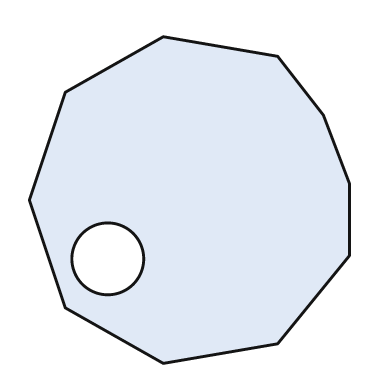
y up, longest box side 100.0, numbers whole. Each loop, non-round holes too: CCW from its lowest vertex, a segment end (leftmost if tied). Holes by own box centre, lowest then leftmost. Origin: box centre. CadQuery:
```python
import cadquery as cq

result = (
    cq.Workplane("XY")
    .moveTo(-8.0, -50.0)
    .lineTo(27.0, -44.0)
    .lineTo(49.0, -17.0)
    .lineTo(49.0, 5.0)
    .lineTo(41.0, 26.0)
    .lineTo(27.0, 44.0)
    .lineTo(-8.0, 50.0)
    .lineTo(-38.0, 33.0)
    .lineTo(-49.0, 0.0)
    .lineTo(-38.0, -33.0)
    .close()
    .moveTo(-25.0, -18.0)
    .circle(11.0)
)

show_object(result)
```